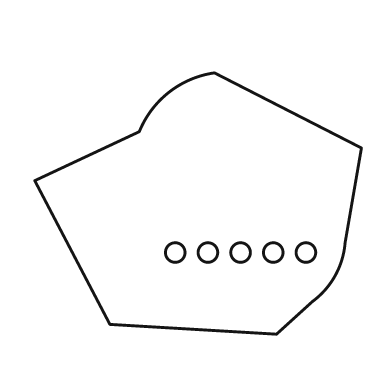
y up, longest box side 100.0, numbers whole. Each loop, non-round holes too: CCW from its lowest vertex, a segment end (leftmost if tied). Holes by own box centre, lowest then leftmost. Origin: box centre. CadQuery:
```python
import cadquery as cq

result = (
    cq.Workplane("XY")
    .moveTo(24.0, -40.0)
    .lineTo(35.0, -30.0)
    .threePointArc((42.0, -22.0), (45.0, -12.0))
    .lineTo(50.0, 17.0)
    .lineTo(5.0, 40.0)
    .threePointArc((-9.0, 34.0), (-18.0, 22.0))
    .lineTo(-50.0, 7.0)
    .lineTo(-27.0, -37.0)
    .close()
    .moveTo(-7.0, -15.0)
    .circle(3.0)
    .moveTo(3.0, -15.0)
    .circle(3.0)
    .moveTo(13.0, -15.0)
    .circle(3.0)
    .moveTo(23.0, -15.0)
    .circle(3.0)
    .moveTo(33.0, -15.0)
    .circle(3.0)
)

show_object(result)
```